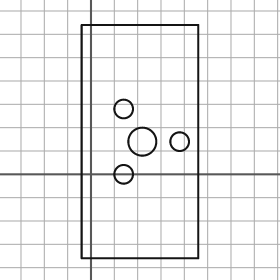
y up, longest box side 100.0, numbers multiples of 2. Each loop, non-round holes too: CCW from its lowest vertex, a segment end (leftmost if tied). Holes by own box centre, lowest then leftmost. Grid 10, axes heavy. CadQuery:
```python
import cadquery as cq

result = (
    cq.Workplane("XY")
    .moveTo(-4.0, -36.0)
    .lineTo(46.0, -36.0)
    .lineTo(46.0, 64.0)
    .lineTo(-4.0, 64.0)
    .close()
    .moveTo(14.0, 0.0)
    .circle(4.0)
    .moveTo(22.0, 14.0)
    .circle(6.0)
    .moveTo(38.0, 14.0)
    .circle(4.0)
    .moveTo(14.0, 28.0)
    .circle(4.0)
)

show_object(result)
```